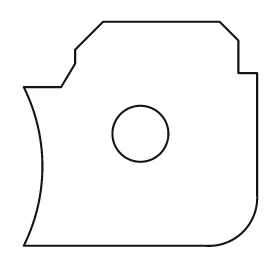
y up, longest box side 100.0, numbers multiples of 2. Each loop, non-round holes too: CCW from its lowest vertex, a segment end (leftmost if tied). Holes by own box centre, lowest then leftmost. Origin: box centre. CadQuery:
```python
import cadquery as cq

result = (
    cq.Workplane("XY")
    .moveTo(-50.0, -48.0)
    .lineTo(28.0, -48.0)
    .threePointArc((44.0, -42.0), (50.0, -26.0))
    .lineTo(50.0, 26.0)
    .lineTo(42.0, 26.0)
    .lineTo(42.0, 40.0)
    .lineTo(34.0, 48.0)
    .lineTo(-16.0, 48.0)
    .lineTo(-28.0, 36.0)
    .lineTo(-28.0, 30.0)
    .lineTo(-34.0, 20.0)
    .lineTo(-50.0, 20.0)
    .threePointArc((-42.0, -14.0), (-50.0, -48.0))
    .close()
    .moveTo(0.0, 0.0)
    .circle(12.0)
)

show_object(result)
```